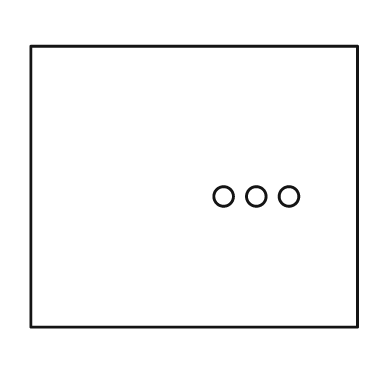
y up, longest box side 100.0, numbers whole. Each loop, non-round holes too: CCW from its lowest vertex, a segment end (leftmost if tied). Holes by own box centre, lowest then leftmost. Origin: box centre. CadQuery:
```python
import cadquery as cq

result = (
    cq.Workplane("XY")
    .moveTo(-50.0, -43.0)
    .lineTo(50.0, -43.0)
    .lineTo(50.0, 43.0)
    .lineTo(-50.0, 43.0)
    .close()
    .moveTo(9.0, -3.0)
    .circle(3.0)
    .moveTo(19.0, -3.0)
    .circle(3.0)
    .moveTo(29.0, -3.0)
    .circle(3.0)
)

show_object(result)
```